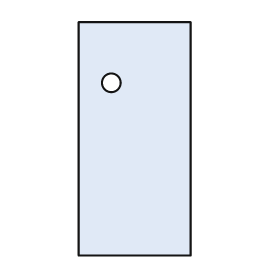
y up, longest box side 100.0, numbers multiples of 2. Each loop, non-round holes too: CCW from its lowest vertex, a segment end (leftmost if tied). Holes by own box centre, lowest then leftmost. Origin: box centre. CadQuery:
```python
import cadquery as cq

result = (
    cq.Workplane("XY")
    .moveTo(-24.0, -50.0)
    .lineTo(24.0, -50.0)
    .lineTo(24.0, 50.0)
    .lineTo(-24.0, 50.0)
    .close()
    .moveTo(-10.0, 24.0)
    .circle(4.0)
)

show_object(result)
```